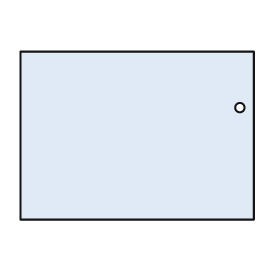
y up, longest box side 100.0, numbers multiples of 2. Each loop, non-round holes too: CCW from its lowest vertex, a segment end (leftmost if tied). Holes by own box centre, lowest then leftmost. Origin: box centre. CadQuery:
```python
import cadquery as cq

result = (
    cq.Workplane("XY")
    .moveTo(-50.0, -36.0)
    .lineTo(50.0, -36.0)
    .lineTo(50.0, 36.0)
    .lineTo(-50.0, 36.0)
    .close()
    .moveTo(44.0, 12.0)
    .circle(2.0)
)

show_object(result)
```